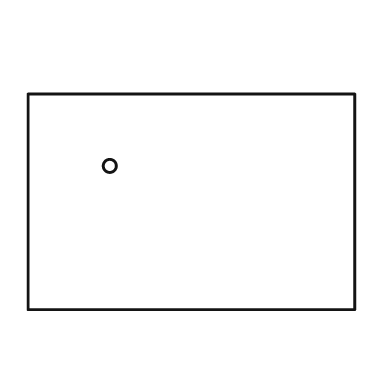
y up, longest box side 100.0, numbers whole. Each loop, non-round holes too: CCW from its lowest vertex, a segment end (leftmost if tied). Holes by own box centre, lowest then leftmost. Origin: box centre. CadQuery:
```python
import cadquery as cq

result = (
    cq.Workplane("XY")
    .moveTo(-50.0, -33.0)
    .lineTo(50.0, -33.0)
    .lineTo(50.0, 33.0)
    .lineTo(-50.0, 33.0)
    .close()
    .moveTo(-25.0, 11.0)
    .circle(2.0)
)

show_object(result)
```